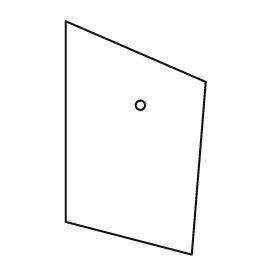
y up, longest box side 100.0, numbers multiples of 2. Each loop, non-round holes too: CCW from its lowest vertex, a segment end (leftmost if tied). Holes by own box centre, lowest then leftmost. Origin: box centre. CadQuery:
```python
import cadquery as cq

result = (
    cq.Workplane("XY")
    .moveTo(24.0, -50.0)
    .lineTo(30.0, 24.0)
    .lineTo(-30.0, 50.0)
    .lineTo(-30.0, -36.0)
    .close()
    .moveTo(2.0, 14.0)
    .circle(2.0)
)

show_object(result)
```